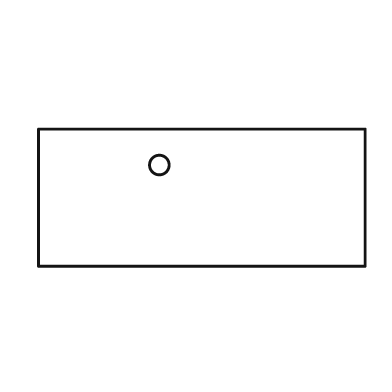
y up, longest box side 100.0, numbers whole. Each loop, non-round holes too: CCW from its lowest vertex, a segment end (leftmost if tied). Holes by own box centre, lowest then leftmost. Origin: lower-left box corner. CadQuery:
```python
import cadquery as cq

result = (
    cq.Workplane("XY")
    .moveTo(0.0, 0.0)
    .lineTo(100.0, 0.0)
    .lineTo(100.0, 42.0)
    .lineTo(0.0, 42.0)
    .close()
    .moveTo(37.0, 31.0)
    .circle(3.0)
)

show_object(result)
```